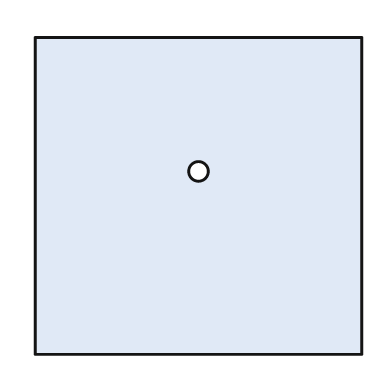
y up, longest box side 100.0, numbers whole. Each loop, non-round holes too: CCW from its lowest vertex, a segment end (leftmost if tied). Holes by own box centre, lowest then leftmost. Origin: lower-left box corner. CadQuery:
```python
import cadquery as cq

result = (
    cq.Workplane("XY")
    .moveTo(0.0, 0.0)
    .lineTo(100.0, 0.0)
    .lineTo(100.0, 97.0)
    .lineTo(0.0, 97.0)
    .close()
    .moveTo(50.0, 56.0)
    .circle(3.0)
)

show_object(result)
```